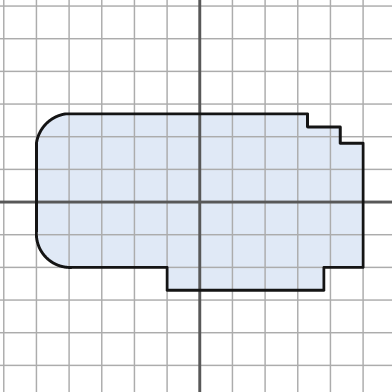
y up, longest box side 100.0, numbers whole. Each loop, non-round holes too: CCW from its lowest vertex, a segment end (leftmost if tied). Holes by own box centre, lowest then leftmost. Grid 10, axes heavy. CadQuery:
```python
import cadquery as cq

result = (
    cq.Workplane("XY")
    .moveTo(-10.0, -27.0)
    .lineTo(38.0, -27.0)
    .lineTo(38.0, -20.0)
    .lineTo(50.0, -20.0)
    .lineTo(50.0, 18.0)
    .lineTo(43.0, 18.0)
    .lineTo(43.0, 23.0)
    .lineTo(33.0, 23.0)
    .lineTo(33.0, 27.0)
    .lineTo(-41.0, 27.0)
    .threePointArc((-47.0, 24.0), (-50.0, 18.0))
    .lineTo(-50.0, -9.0)
    .threePointArc((-47.0, -17.0), (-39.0, -20.0))
    .lineTo(-10.0, -20.0)
    .close()
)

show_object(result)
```